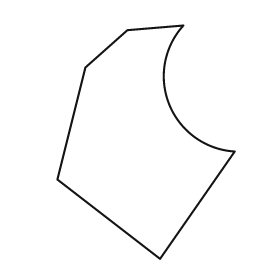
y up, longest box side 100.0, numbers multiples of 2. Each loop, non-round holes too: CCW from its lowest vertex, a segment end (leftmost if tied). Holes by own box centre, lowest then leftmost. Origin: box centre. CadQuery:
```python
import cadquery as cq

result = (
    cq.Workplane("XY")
    .moveTo(6.0, -50.0)
    .lineTo(38.0, -4.0)
    .threePointArc((10.0, 16.0), (16.0, 50.0))
    .lineTo(-8.0, 48.0)
    .lineTo(-26.0, 32.0)
    .lineTo(-38.0, -16.0)
    .close()
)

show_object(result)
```